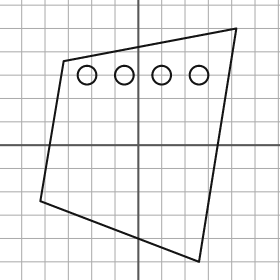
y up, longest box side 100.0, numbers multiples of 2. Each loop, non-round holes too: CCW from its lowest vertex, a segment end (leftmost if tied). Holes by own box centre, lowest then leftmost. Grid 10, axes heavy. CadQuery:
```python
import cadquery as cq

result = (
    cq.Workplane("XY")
    .moveTo(26.0, -50.0)
    .lineTo(42.0, 50.0)
    .lineTo(-32.0, 36.0)
    .lineTo(-42.0, -24.0)
    .close()
    .moveTo(-22.0, 30.0)
    .circle(4.0)
    .moveTo(-6.0, 30.0)
    .circle(4.0)
    .moveTo(10.0, 30.0)
    .circle(4.0)
    .moveTo(26.0, 30.0)
    .circle(4.0)
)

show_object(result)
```